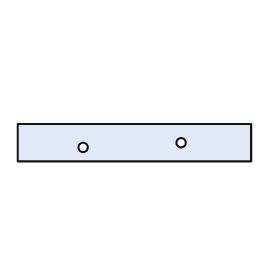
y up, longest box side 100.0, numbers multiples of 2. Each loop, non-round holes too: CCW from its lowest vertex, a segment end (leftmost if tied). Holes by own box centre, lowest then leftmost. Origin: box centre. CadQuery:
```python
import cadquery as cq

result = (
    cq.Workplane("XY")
    .moveTo(-50.0, -8.0)
    .lineTo(50.0, -8.0)
    .lineTo(50.0, 8.0)
    .lineTo(-50.0, 8.0)
    .close()
    .moveTo(-22.0, -2.0)
    .circle(2.0)
    .moveTo(20.0, 0.0)
    .circle(2.0)
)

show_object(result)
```